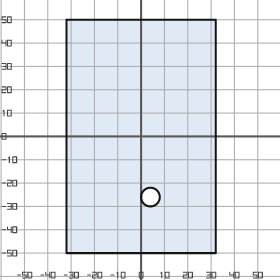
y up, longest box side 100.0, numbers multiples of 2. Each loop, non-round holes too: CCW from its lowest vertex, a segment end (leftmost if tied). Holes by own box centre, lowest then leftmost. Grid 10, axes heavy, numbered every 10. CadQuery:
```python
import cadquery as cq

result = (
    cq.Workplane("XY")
    .moveTo(-32.0, -50.0)
    .lineTo(32.0, -50.0)
    .lineTo(32.0, 50.0)
    .lineTo(-32.0, 50.0)
    .close()
    .moveTo(4.0, -26.0)
    .circle(4.0)
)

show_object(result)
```